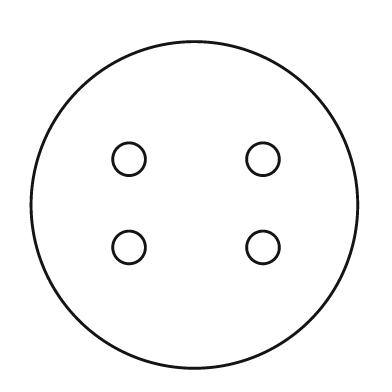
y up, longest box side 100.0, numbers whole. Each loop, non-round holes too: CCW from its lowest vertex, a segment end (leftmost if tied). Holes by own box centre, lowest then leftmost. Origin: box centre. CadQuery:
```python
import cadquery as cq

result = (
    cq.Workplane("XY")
    .moveTo(0.0, 0.0)
    .circle(50.0)
    .moveTo(-20.0, -13.0)
    .circle(5.0)
    .moveTo(21.0, -13.0)
    .circle(5.0)
    .moveTo(-20.0, 14.0)
    .circle(5.0)
    .moveTo(21.0, 14.0)
    .circle(5.0)
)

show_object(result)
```